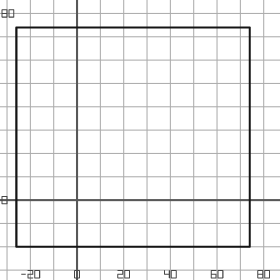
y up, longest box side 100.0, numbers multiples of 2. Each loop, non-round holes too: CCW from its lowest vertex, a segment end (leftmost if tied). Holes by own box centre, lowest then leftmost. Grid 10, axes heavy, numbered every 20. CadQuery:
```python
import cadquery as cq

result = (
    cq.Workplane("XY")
    .moveTo(-26.0, -20.0)
    .lineTo(74.0, -20.0)
    .lineTo(74.0, 74.0)
    .lineTo(-26.0, 74.0)
    .close()
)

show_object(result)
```